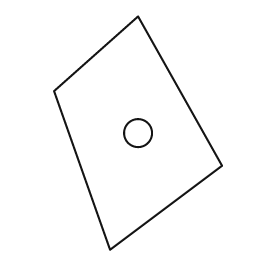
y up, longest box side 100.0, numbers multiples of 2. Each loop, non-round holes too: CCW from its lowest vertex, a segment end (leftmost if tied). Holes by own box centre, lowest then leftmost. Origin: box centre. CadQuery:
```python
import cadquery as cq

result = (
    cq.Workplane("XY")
    .moveTo(-12.0, -50.0)
    .lineTo(36.0, -14.0)
    .lineTo(0.0, 50.0)
    .lineTo(-36.0, 18.0)
    .close()
    .moveTo(0.0, 0.0)
    .circle(6.0)
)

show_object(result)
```